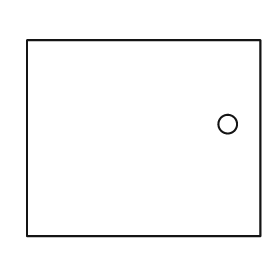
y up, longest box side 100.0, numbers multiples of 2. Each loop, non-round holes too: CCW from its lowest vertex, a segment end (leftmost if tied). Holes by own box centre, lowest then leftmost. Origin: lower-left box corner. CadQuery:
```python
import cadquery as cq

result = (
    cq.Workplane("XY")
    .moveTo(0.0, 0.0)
    .lineTo(100.0, 0.0)
    .lineTo(100.0, 84.0)
    .lineTo(0.0, 84.0)
    .close()
    .moveTo(86.0, 48.0)
    .circle(4.0)
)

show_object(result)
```